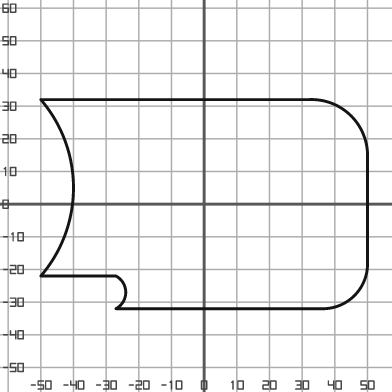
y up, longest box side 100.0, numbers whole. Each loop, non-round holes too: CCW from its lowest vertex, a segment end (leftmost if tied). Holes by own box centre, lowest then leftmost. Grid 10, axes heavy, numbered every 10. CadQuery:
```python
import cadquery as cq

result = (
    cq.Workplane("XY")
    .moveTo(-27.0, -32.0)
    .lineTo(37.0, -32.0)
    .threePointArc((46.0, -28.0), (50.0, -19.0))
    .lineTo(50.0, 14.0)
    .threePointArc((45.0, 27.0), (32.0, 32.0))
    .lineTo(-50.0, 32.0)
    .threePointArc((-40.0, 5.0), (-50.0, -22.0))
    .lineTo(-27.0, -22.0)
    .threePointArc((-24.0, -27.0), (-27.0, -32.0))
    .close()
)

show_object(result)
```